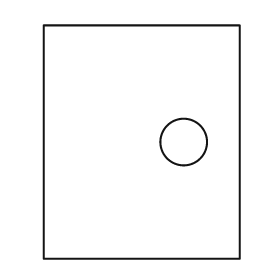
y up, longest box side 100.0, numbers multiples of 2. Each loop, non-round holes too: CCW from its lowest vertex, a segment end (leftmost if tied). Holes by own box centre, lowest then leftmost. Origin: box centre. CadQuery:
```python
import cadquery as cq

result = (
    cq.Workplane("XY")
    .moveTo(-42.0, -50.0)
    .lineTo(42.0, -50.0)
    .lineTo(42.0, 50.0)
    .lineTo(-42.0, 50.0)
    .close()
    .moveTo(18.0, 0.0)
    .circle(10.0)
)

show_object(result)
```